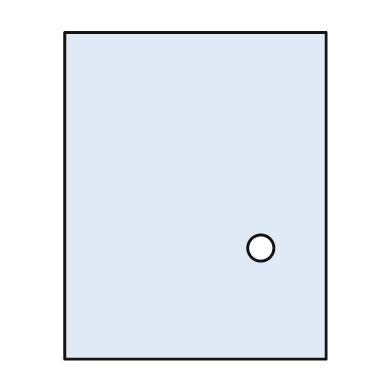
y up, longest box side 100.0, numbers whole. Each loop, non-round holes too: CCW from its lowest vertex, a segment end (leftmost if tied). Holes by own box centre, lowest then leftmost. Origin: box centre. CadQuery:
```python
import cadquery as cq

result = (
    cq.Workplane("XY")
    .moveTo(-40.0, -50.0)
    .lineTo(40.0, -50.0)
    .lineTo(40.0, 50.0)
    .lineTo(-40.0, 50.0)
    .close()
    .moveTo(20.0, -16.0)
    .circle(4.0)
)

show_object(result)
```